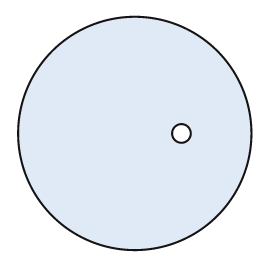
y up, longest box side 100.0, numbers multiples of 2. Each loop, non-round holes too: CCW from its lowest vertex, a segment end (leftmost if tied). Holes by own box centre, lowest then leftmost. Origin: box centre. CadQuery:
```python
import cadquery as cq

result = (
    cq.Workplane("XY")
    .moveTo(0.0, 0.0)
    .circle(50.0)
    .moveTo(20.0, 0.0)
    .circle(4.0)
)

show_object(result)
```